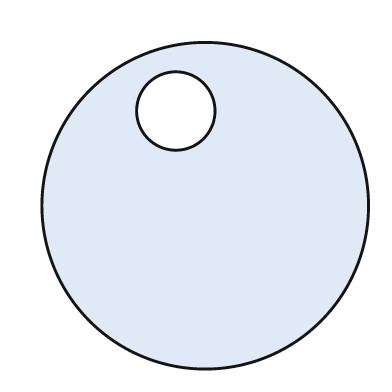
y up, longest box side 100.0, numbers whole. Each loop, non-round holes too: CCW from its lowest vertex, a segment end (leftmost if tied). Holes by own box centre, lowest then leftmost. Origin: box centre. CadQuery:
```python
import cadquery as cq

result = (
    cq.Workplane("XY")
    .moveTo(0.0, 0.0)
    .circle(50.0)
    .moveTo(-9.0, 29.0)
    .circle(12.0)
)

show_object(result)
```